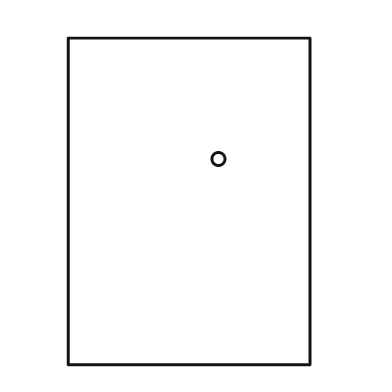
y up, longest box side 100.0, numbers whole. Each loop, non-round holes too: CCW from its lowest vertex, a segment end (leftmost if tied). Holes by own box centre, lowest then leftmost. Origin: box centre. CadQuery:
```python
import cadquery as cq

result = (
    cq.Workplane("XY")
    .moveTo(-37.0, -50.0)
    .lineTo(37.0, -50.0)
    .lineTo(37.0, 50.0)
    .lineTo(-37.0, 50.0)
    .close()
    .moveTo(9.0, 13.0)
    .circle(2.0)
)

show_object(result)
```